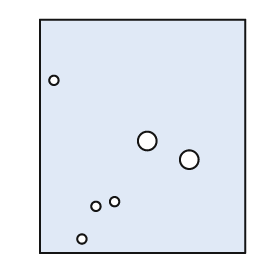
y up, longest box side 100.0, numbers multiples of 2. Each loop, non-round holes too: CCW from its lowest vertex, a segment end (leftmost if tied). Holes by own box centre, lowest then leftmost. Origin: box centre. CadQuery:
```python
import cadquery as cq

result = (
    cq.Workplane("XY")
    .moveTo(-44.0, -50.0)
    .lineTo(44.0, -50.0)
    .lineTo(44.0, 50.0)
    .lineTo(-44.0, 50.0)
    .close()
    .moveTo(-26.0, -44.0)
    .circle(2.0)
    .moveTo(-20.0, -30.0)
    .circle(2.0)
    .moveTo(-12.0, -28.0)
    .circle(2.0)
    .moveTo(20.0, -10.0)
    .circle(4.0)
    .moveTo(2.0, -2.0)
    .circle(4.0)
    .moveTo(-38.0, 24.0)
    .circle(2.0)
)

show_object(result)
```